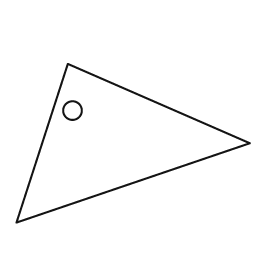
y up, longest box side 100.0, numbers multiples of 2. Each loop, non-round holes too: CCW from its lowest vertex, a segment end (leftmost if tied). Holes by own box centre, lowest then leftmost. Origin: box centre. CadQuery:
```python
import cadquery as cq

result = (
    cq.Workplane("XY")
    .moveTo(-50.0, -34.0)
    .lineTo(50.0, 0.0)
    .lineTo(-28.0, 34.0)
    .close()
    .moveTo(-26.0, 14.0)
    .circle(4.0)
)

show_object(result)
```